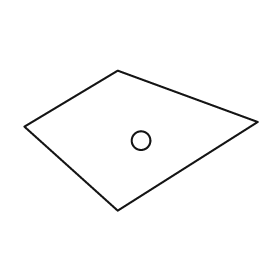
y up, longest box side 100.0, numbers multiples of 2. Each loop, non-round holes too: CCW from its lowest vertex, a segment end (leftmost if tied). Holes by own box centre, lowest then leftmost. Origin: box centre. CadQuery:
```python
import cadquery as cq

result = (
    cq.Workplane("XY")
    .moveTo(-10.0, -30.0)
    .lineTo(50.0, 8.0)
    .lineTo(-10.0, 30.0)
    .lineTo(-50.0, 6.0)
    .close()
    .moveTo(0.0, 0.0)
    .circle(4.0)
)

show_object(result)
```